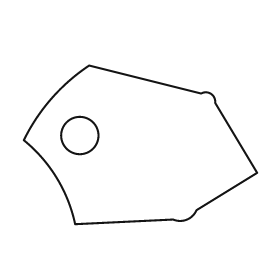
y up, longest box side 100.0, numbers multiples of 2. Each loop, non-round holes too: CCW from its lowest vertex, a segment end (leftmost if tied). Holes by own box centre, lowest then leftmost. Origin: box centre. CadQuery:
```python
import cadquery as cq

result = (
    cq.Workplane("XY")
    .moveTo(-28.0, -34.0)
    .lineTo(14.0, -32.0)
    .threePointArc((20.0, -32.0), (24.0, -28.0))
    .lineTo(50.0, -12.0)
    .lineTo(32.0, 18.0)
    .threePointArc((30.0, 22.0), (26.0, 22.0))
    .lineTo(-22.0, 34.0)
    .threePointArc((-38.0, 20.0), (-50.0, 2.0))
    .threePointArc((-36.0, -14.0), (-28.0, -34.0))
    .close()
    .moveTo(-26.0, 4.0)
    .circle(8.0)
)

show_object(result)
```